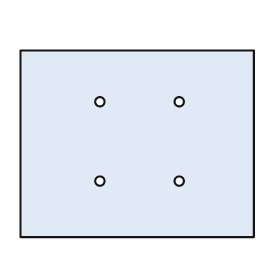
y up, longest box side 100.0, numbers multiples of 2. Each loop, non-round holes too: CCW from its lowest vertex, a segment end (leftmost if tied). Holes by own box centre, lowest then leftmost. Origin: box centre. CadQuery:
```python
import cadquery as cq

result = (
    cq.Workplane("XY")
    .moveTo(-50.0, -40.0)
    .lineTo(50.0, -40.0)
    .lineTo(50.0, 40.0)
    .lineTo(-50.0, 40.0)
    .close()
    .moveTo(-16.0, -16.0)
    .circle(2.0)
    .moveTo(18.0, -16.0)
    .circle(2.0)
    .moveTo(-16.0, 18.0)
    .circle(2.0)
    .moveTo(18.0, 18.0)
    .circle(2.0)
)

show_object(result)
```